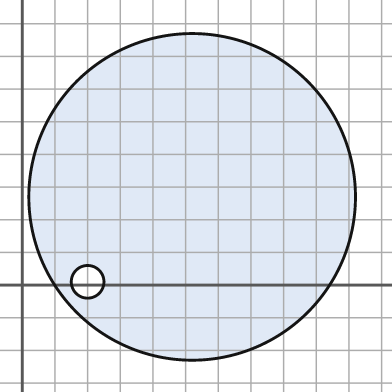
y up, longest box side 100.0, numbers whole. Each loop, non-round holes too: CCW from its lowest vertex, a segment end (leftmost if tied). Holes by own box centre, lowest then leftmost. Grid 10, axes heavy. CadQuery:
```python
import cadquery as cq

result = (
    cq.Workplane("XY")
    .moveTo(52.0, 27.0)
    .circle(50.0)
    .moveTo(20.0, 1.0)
    .circle(5.0)
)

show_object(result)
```